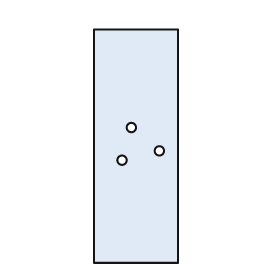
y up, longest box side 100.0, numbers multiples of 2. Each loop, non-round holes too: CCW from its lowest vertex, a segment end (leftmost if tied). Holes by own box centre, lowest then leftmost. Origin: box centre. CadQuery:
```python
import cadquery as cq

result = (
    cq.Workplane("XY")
    .moveTo(-18.0, -50.0)
    .lineTo(18.0, -50.0)
    .lineTo(18.0, 50.0)
    .lineTo(-18.0, 50.0)
    .close()
    .moveTo(-6.0, -6.0)
    .circle(2.0)
    .moveTo(10.0, -2.0)
    .circle(2.0)
    .moveTo(-2.0, 8.0)
    .circle(2.0)
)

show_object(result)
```